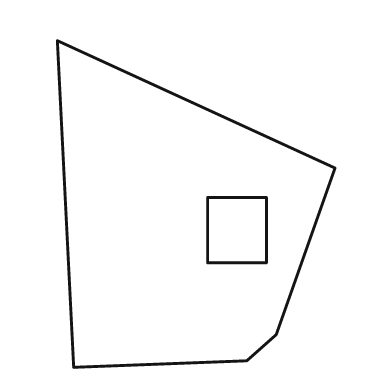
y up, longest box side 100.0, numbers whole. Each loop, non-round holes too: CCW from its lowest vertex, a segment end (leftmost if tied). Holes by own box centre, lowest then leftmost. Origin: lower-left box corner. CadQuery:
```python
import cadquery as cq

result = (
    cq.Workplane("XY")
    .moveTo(5.0, 0.0)
    .lineTo(58.0, 2.0)
    .lineTo(67.0, 10.0)
    .lineTo(85.0, 61.0)
    .lineTo(0.0, 100.0)
    .close()
    .moveTo(46.0, 32.0)
    .lineTo(64.0, 32.0)
    .lineTo(64.0, 52.0)
    .lineTo(46.0, 52.0)
    .close()
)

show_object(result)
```